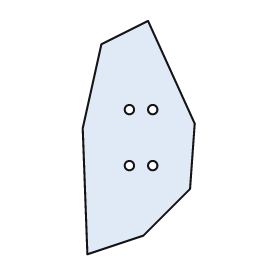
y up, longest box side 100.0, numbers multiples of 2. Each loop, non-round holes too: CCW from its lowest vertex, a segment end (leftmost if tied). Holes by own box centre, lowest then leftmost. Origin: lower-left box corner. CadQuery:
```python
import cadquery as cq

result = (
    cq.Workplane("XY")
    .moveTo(2.0, 0.0)
    .lineTo(26.0, 8.0)
    .lineTo(46.0, 28.0)
    .lineTo(48.0, 56.0)
    .lineTo(28.0, 100.0)
    .lineTo(8.0, 90.0)
    .lineTo(0.0, 54.0)
    .close()
    .moveTo(20.0, 38.0)
    .circle(2.0)
    .moveTo(30.0, 38.0)
    .circle(2.0)
    .moveTo(20.0, 62.0)
    .circle(2.0)
    .moveTo(30.0, 62.0)
    .circle(2.0)
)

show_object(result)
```